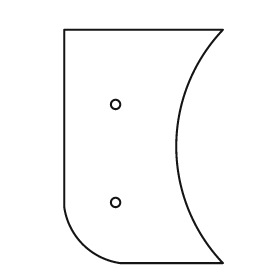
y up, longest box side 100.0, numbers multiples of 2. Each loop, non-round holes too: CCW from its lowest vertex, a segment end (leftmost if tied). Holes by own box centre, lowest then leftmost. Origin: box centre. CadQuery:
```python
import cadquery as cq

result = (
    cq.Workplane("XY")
    .moveTo(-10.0, -50.0)
    .lineTo(34.0, -50.0)
    .threePointArc((14.0, 0.0), (34.0, 50.0))
    .lineTo(-34.0, 50.0)
    .lineTo(-34.0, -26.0)
    .threePointArc((-26.0, -42.0), (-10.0, -50.0))
    .close()
    .moveTo(-12.0, -24.0)
    .circle(2.0)
    .moveTo(-12.0, 18.0)
    .circle(2.0)
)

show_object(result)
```